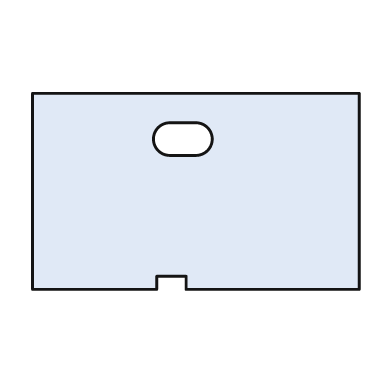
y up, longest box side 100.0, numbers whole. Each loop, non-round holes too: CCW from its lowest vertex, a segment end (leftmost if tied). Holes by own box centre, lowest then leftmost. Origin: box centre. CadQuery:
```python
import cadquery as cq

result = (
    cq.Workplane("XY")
    .moveTo(-50.0, -30.0)
    .lineTo(-12.0, -30.0)
    .lineTo(-12.0, -26.0)
    .lineTo(-3.0, -26.0)
    .lineTo(-3.0, -30.0)
    .lineTo(50.0, -30.0)
    .lineTo(50.0, 30.0)
    .lineTo(-50.0, 30.0)
    .close()
    .moveTo(-8.0, 11.0)
    .lineTo(0.0, 11.0)
    .threePointArc((5.0, 16.0), (0.0, 21.0))
    .lineTo(-8.0, 21.0)
    .threePointArc((-13.0, 16.0), (-8.0, 11.0))
    .close()
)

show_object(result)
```